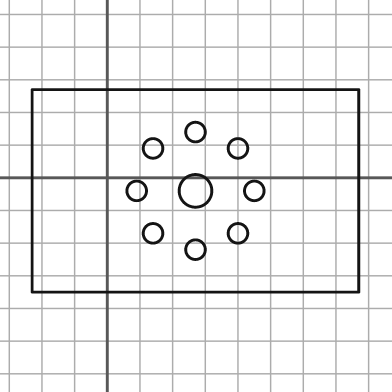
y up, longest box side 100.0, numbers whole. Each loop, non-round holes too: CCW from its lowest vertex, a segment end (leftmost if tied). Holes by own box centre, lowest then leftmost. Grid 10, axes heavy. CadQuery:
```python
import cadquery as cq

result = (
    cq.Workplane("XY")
    .moveTo(-23.0, -35.0)
    .lineTo(77.0, -35.0)
    .lineTo(77.0, 27.0)
    .lineTo(-23.0, 27.0)
    .close()
    .moveTo(27.0, -22.0)
    .circle(3.0)
    .moveTo(14.0, -17.0)
    .circle(3.0)
    .moveTo(40.0, -17.0)
    .circle(3.0)
    .moveTo(9.0, -4.0)
    .circle(3.0)
    .moveTo(27.0, -4.0)
    .circle(5.0)
    .moveTo(45.0, -4.0)
    .circle(3.0)
    .moveTo(14.0, 9.0)
    .circle(3.0)
    .moveTo(40.0, 9.0)
    .circle(3.0)
    .moveTo(27.0, 14.0)
    .circle(3.0)
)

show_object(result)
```